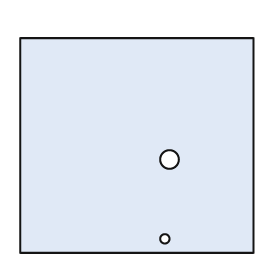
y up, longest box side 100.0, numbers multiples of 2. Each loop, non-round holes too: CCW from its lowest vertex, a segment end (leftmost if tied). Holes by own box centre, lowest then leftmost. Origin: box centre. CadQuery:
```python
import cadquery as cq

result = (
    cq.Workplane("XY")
    .moveTo(-50.0, -46.0)
    .lineTo(50.0, -46.0)
    .lineTo(50.0, 46.0)
    .lineTo(-50.0, 46.0)
    .close()
    .moveTo(12.0, -40.0)
    .circle(2.0)
    .moveTo(14.0, -6.0)
    .circle(4.0)
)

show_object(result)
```